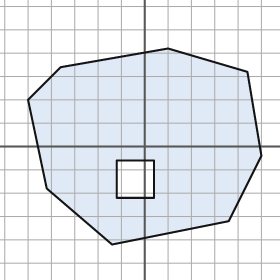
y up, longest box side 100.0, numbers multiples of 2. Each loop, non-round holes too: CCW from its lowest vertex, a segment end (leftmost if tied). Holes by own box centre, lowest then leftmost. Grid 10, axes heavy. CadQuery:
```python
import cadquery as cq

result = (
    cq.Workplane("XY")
    .moveTo(-14.0, -42.0)
    .lineTo(36.0, -32.0)
    .lineTo(50.0, -4.0)
    .lineTo(44.0, 32.0)
    .lineTo(10.0, 42.0)
    .lineTo(-36.0, 34.0)
    .lineTo(-50.0, 20.0)
    .lineTo(-42.0, -18.0)
    .close()
    .moveTo(-12.0, -22.0)
    .lineTo(4.0, -22.0)
    .lineTo(4.0, -6.0)
    .lineTo(-12.0, -6.0)
    .close()
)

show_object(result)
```